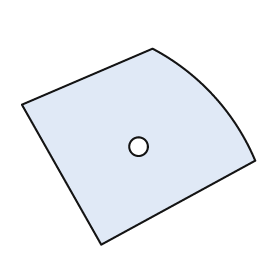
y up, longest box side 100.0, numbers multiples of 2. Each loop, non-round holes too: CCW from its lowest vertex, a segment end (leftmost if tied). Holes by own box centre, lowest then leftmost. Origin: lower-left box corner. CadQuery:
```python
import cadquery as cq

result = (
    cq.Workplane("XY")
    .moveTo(34.0, 0.0)
    .lineTo(100.0, 36.0)
    .threePointArc((82.0, 64.0), (56.0, 84.0))
    .lineTo(0.0, 60.0)
    .close()
    .moveTo(50.0, 42.0)
    .circle(4.0)
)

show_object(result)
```